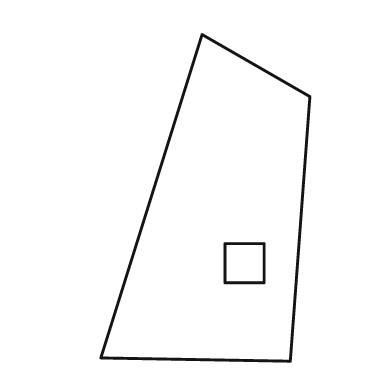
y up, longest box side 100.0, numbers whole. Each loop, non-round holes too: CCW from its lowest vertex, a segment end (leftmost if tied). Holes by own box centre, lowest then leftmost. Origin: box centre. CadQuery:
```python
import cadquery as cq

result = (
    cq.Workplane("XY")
    .moveTo(26.0, -50.0)
    .lineTo(32.0, 31.0)
    .lineTo(-1.0, 50.0)
    .lineTo(-32.0, -49.0)
    .close()
    .moveTo(6.0, -26.0)
    .lineTo(18.0, -26.0)
    .lineTo(18.0, -14.0)
    .lineTo(6.0, -14.0)
    .close()
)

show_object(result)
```